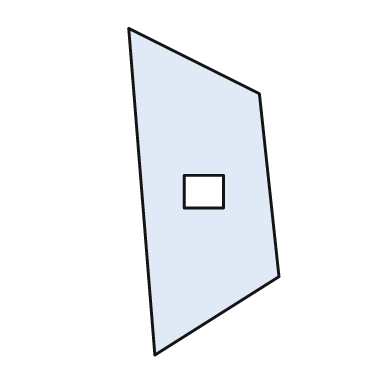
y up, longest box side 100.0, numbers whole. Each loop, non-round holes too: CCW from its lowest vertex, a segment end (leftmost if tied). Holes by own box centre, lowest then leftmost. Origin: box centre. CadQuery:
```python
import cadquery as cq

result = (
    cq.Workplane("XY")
    .moveTo(-15.0, -50.0)
    .lineTo(23.0, -26.0)
    .lineTo(17.0, 30.0)
    .lineTo(-23.0, 50.0)
    .close()
    .moveTo(-6.0, -5.0)
    .lineTo(6.0, -5.0)
    .lineTo(6.0, 5.0)
    .lineTo(-6.0, 5.0)
    .close()
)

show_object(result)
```